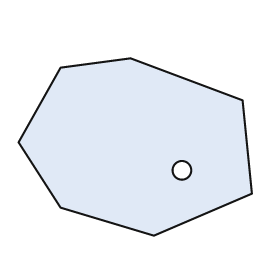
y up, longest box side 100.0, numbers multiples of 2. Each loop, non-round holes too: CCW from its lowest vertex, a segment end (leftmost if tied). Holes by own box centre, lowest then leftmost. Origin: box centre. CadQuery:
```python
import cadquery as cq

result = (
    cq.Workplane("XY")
    .moveTo(8.0, -38.0)
    .lineTo(50.0, -20.0)
    .lineTo(46.0, 20.0)
    .lineTo(-2.0, 38.0)
    .lineTo(-32.0, 34.0)
    .lineTo(-50.0, 2.0)
    .lineTo(-32.0, -26.0)
    .close()
    .moveTo(20.0, -10.0)
    .circle(4.0)
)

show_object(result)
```